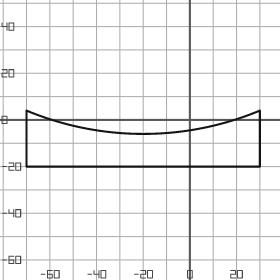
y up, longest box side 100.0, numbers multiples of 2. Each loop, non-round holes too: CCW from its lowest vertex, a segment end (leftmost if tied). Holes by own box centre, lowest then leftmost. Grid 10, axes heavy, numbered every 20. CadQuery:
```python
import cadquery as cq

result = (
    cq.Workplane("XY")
    .moveTo(-70.0, -20.0)
    .lineTo(30.0, -20.0)
    .lineTo(30.0, 4.0)
    .threePointArc((-20.0, -6.0), (-70.0, 4.0))
    .close()
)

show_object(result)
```